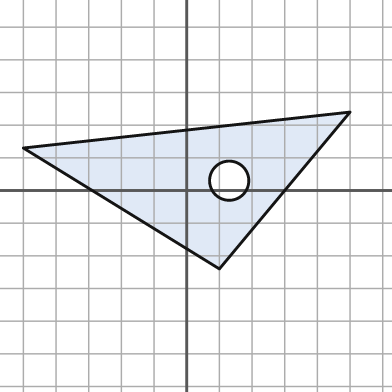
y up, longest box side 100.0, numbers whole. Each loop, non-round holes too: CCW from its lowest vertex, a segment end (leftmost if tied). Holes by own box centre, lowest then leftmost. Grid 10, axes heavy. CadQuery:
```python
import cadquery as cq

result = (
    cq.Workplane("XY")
    .moveTo(10.0, -24.0)
    .lineTo(50.0, 24.0)
    .lineTo(-50.0, 13.0)
    .close()
    .moveTo(13.0, 3.0)
    .circle(6.0)
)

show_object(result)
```